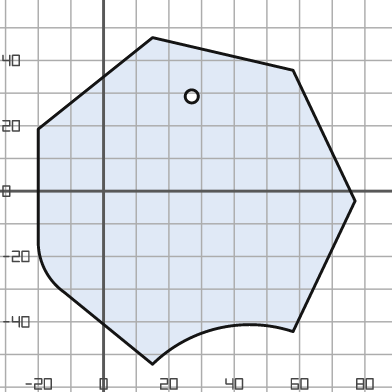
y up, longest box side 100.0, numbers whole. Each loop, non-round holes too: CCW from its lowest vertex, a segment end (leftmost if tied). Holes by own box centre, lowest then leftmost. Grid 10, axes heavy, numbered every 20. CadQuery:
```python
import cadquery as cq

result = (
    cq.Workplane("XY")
    .moveTo(15.0, -53.0)
    .threePointArc((35.0, -42.0), (58.0, -43.0))
    .lineTo(77.0, -3.0)
    .lineTo(58.0, 37.0)
    .lineTo(15.0, 47.0)
    .lineTo(-20.0, 19.0)
    .lineTo(-20.0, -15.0)
    .threePointArc((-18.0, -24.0), (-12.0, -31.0))
    .close()
    .moveTo(27.0, 29.0)
    .circle(2.0)
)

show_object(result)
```